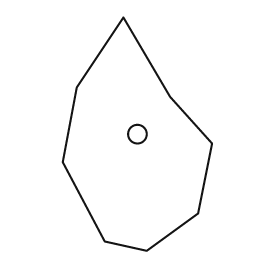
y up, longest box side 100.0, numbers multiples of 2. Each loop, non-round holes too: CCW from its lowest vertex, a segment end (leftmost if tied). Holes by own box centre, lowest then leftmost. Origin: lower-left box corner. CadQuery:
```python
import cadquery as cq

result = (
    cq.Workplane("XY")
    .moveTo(36.0, 0.0)
    .lineTo(58.0, 16.0)
    .lineTo(64.0, 46.0)
    .lineTo(46.0, 66.0)
    .lineTo(26.0, 100.0)
    .lineTo(6.0, 70.0)
    .lineTo(0.0, 38.0)
    .lineTo(18.0, 4.0)
    .close()
    .moveTo(32.0, 50.0)
    .circle(4.0)
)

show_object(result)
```